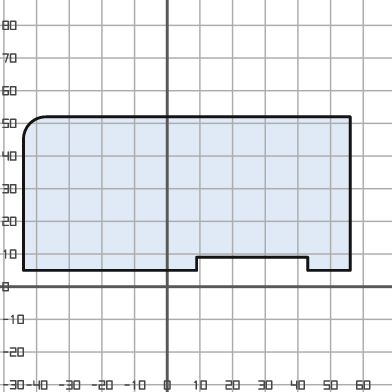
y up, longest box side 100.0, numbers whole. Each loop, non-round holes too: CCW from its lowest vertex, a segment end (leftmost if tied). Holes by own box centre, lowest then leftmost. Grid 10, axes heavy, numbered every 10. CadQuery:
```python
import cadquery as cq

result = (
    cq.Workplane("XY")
    .moveTo(-44.0, 5.0)
    .lineTo(9.0, 5.0)
    .lineTo(9.0, 9.0)
    .lineTo(43.0, 9.0)
    .lineTo(43.0, 5.0)
    .lineTo(56.0, 5.0)
    .lineTo(56.0, 52.0)
    .lineTo(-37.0, 52.0)
    .threePointArc((-42.0, 50.0), (-44.0, 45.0))
    .close()
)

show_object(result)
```